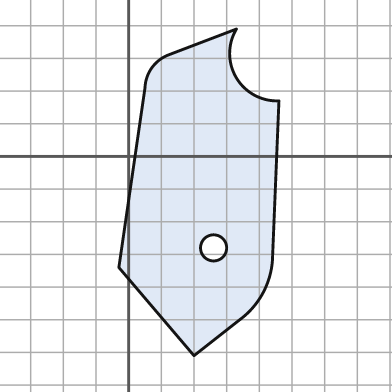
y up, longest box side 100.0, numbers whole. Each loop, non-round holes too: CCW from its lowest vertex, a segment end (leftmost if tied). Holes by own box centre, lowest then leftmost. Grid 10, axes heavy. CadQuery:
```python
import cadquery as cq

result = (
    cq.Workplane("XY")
    .moveTo(20.0, -61.0)
    .lineTo(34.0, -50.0)
    .threePointArc((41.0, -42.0), (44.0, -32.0))
    .lineTo(46.0, 17.0)
    .threePointArc((33.0, 24.0), (33.0, 39.0))
    .lineTo(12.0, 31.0)
    .threePointArc((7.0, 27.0), (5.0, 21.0))
    .lineTo(-3.0, -34.0)
    .close()
    .moveTo(26.0, -28.0)
    .circle(4.0)
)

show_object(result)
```